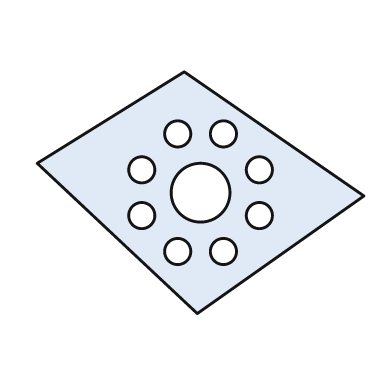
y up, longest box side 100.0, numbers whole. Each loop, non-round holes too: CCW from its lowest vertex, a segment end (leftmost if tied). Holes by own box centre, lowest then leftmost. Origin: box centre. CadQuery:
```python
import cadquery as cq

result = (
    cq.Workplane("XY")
    .moveTo(-1.0, -37.0)
    .lineTo(50.0, -1.0)
    .lineTo(-5.0, 37.0)
    .lineTo(-50.0, 9.0)
    .close()
    .moveTo(-7.0, -18.0)
    .circle(4.0)
    .moveTo(7.0, -18.0)
    .circle(4.0)
    .moveTo(-18.0, -7.0)
    .circle(4.0)
    .moveTo(18.0, -7.0)
    .circle(4.0)
    .moveTo(0.0, 0.0)
    .circle(9.0)
    .moveTo(-18.0, 7.0)
    .circle(4.0)
    .moveTo(18.0, 7.0)
    .circle(4.0)
    .moveTo(-7.0, 18.0)
    .circle(4.0)
    .moveTo(7.0, 18.0)
    .circle(4.0)
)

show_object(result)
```